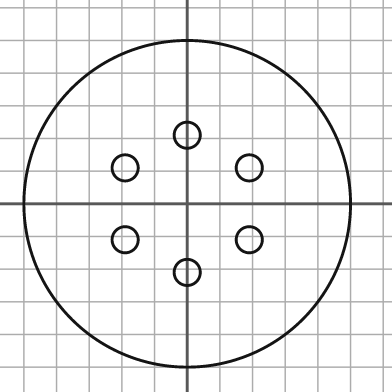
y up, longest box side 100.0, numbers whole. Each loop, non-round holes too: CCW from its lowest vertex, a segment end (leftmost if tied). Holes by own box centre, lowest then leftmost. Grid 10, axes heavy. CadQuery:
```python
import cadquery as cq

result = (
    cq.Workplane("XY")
    .moveTo(0.0, 0.0)
    .circle(50.0)
    .moveTo(0.0, -21.0)
    .circle(4.0)
    .moveTo(-19.0, -11.0)
    .circle(4.0)
    .moveTo(19.0, -11.0)
    .circle(4.0)
    .moveTo(-19.0, 11.0)
    .circle(4.0)
    .moveTo(19.0, 11.0)
    .circle(4.0)
    .moveTo(0.0, 21.0)
    .circle(4.0)
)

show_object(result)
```